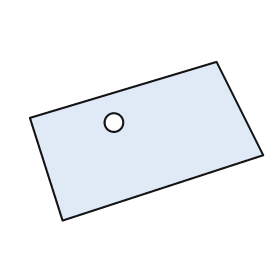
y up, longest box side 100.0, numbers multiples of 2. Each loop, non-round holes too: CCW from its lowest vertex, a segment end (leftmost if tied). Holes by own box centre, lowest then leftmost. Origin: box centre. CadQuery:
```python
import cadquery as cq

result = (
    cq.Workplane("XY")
    .moveTo(-36.0, -34.0)
    .lineTo(50.0, -6.0)
    .lineTo(30.0, 34.0)
    .lineTo(-50.0, 10.0)
    .close()
    .moveTo(-14.0, 8.0)
    .circle(4.0)
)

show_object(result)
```